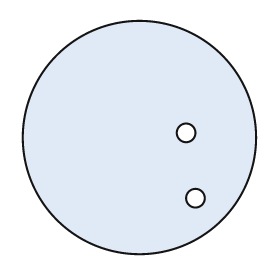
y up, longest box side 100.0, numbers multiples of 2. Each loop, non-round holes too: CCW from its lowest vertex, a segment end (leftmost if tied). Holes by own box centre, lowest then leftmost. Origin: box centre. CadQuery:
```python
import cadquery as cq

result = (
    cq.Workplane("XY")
    .moveTo(0.0, 0.0)
    .circle(50.0)
    .moveTo(24.0, -26.0)
    .circle(4.0)
    .moveTo(20.0, 2.0)
    .circle(4.0)
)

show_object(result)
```